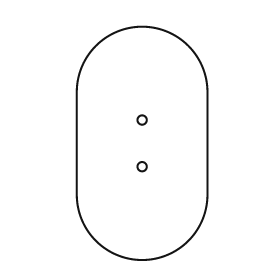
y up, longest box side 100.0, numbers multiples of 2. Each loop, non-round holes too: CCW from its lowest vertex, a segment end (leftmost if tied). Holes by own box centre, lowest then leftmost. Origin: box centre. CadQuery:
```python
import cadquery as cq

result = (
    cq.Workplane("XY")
    .moveTo(-28.0, -22.0)
    .threePointArc((0.0, -50.0), (28.0, -22.0))
    .lineTo(28.0, 22.0)
    .threePointArc((0.0, 50.0), (-28.0, 22.0))
    .close()
    .moveTo(0.0, -10.0)
    .circle(2.0)
    .moveTo(0.0, 10.0)
    .circle(2.0)
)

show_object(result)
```